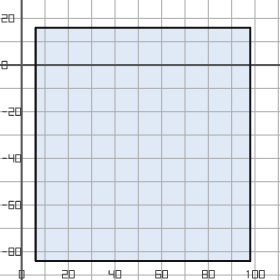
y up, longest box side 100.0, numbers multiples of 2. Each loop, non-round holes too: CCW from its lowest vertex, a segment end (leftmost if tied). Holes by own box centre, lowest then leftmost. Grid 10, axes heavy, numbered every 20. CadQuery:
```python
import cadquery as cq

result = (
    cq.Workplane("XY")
    .moveTo(6.0, -84.0)
    .lineTo(98.0, -84.0)
    .lineTo(98.0, 16.0)
    .lineTo(6.0, 16.0)
    .close()
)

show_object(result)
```